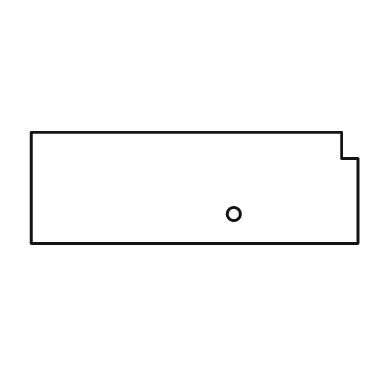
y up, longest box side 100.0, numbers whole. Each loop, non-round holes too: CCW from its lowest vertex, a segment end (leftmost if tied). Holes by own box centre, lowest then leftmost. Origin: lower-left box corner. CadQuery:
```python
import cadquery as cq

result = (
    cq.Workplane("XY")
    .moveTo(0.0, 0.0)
    .lineTo(100.0, 0.0)
    .lineTo(100.0, 26.0)
    .lineTo(95.0, 26.0)
    .lineTo(95.0, 34.0)
    .lineTo(0.0, 34.0)
    .close()
    .moveTo(62.0, 9.0)
    .circle(2.0)
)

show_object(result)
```